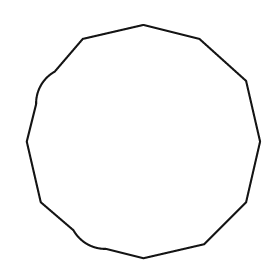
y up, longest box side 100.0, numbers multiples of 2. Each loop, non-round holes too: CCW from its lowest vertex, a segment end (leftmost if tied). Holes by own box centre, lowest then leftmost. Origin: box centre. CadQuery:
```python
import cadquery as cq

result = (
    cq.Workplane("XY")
    .moveTo(0.0, -50.0)
    .lineTo(26.0, -44.0)
    .lineTo(44.0, -26.0)
    .lineTo(50.0, 0.0)
    .lineTo(44.0, 26.0)
    .lineTo(24.0, 44.0)
    .lineTo(0.0, 50.0)
    .lineTo(-26.0, 44.0)
    .lineTo(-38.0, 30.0)
    .threePointArc((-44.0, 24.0), (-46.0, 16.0))
    .lineTo(-50.0, 0.0)
    .lineTo(-44.0, -26.0)
    .lineTo(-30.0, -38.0)
    .threePointArc((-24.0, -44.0), (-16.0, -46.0))
    .close()
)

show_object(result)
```